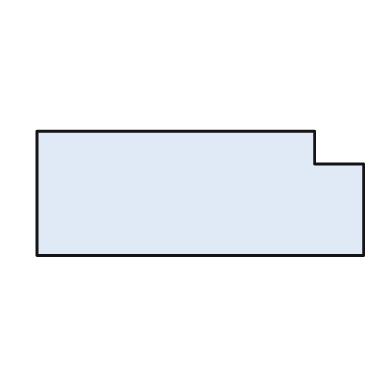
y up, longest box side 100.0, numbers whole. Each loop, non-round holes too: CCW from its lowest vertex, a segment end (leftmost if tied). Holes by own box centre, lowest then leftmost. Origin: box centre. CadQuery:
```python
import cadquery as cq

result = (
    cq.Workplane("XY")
    .moveTo(-50.0, -19.0)
    .lineTo(50.0, -19.0)
    .lineTo(50.0, 9.0)
    .lineTo(35.0, 9.0)
    .lineTo(35.0, 19.0)
    .lineTo(-50.0, 19.0)
    .close()
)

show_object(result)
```